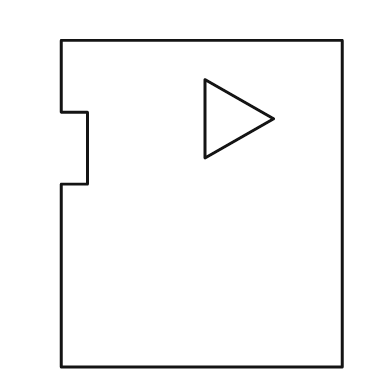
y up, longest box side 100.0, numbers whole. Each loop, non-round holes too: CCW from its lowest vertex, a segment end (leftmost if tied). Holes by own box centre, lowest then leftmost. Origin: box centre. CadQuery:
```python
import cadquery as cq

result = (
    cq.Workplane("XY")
    .moveTo(-43.0, -50.0)
    .lineTo(43.0, -50.0)
    .lineTo(43.0, 50.0)
    .lineTo(-43.0, 50.0)
    .lineTo(-43.0, 28.0)
    .lineTo(-35.0, 28.0)
    .lineTo(-35.0, 6.0)
    .lineTo(-43.0, 6.0)
    .close()
    .moveTo(1.0, 14.0)
    .lineTo(22.0, 26.0)
    .lineTo(1.0, 38.0)
    .close()
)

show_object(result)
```